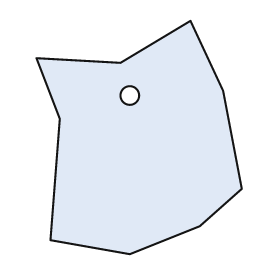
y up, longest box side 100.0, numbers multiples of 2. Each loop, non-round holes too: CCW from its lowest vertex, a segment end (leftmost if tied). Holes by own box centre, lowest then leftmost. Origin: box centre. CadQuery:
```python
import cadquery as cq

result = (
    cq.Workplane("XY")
    .moveTo(-4.0, -50.0)
    .lineTo(26.0, -38.0)
    .lineTo(44.0, -22.0)
    .lineTo(36.0, 20.0)
    .lineTo(22.0, 50.0)
    .lineTo(-8.0, 32.0)
    .lineTo(-44.0, 34.0)
    .lineTo(-34.0, 8.0)
    .lineTo(-38.0, -44.0)
    .close()
    .moveTo(-4.0, 18.0)
    .circle(4.0)
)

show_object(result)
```